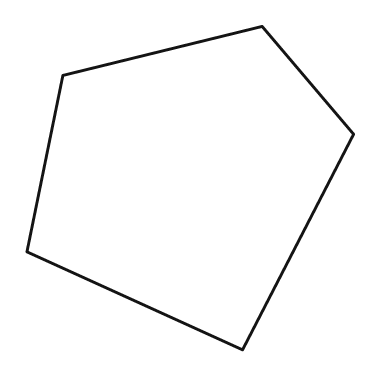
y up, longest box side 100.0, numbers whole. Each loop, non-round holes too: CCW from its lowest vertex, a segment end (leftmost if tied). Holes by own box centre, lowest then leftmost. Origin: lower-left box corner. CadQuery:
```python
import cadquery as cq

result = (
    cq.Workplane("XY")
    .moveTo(66.0, 0.0)
    .lineTo(100.0, 66.0)
    .lineTo(72.0, 99.0)
    .lineTo(11.0, 84.0)
    .lineTo(0.0, 30.0)
    .close()
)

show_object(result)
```